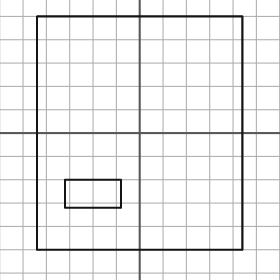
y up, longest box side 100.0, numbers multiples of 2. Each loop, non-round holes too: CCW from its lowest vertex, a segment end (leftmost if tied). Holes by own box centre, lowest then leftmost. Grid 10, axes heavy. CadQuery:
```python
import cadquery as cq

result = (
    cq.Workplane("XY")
    .moveTo(-44.0, -50.0)
    .lineTo(44.0, -50.0)
    .lineTo(44.0, 50.0)
    .lineTo(-44.0, 50.0)
    .close()
    .moveTo(-32.0, -32.0)
    .lineTo(-8.0, -32.0)
    .lineTo(-8.0, -20.0)
    .lineTo(-32.0, -20.0)
    .close()
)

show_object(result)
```